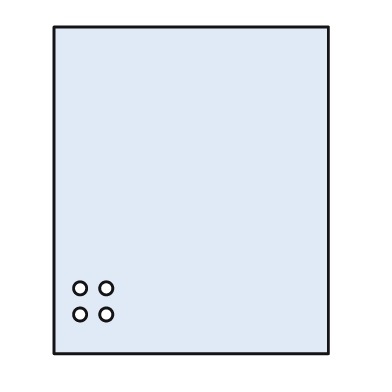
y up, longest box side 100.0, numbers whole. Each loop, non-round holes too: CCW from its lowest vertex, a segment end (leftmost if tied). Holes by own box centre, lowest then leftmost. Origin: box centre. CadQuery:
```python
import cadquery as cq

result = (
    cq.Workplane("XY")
    .moveTo(-42.0, -50.0)
    .lineTo(42.0, -50.0)
    .lineTo(42.0, 50.0)
    .lineTo(-42.0, 50.0)
    .close()
    .moveTo(-34.0, -38.0)
    .circle(2.0)
    .moveTo(-26.0, -38.0)
    .circle(2.0)
    .moveTo(-34.0, -30.0)
    .circle(2.0)
    .moveTo(-26.0, -30.0)
    .circle(2.0)
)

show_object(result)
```